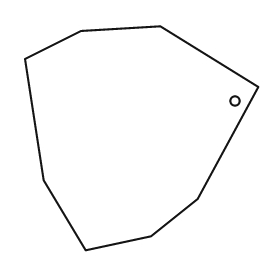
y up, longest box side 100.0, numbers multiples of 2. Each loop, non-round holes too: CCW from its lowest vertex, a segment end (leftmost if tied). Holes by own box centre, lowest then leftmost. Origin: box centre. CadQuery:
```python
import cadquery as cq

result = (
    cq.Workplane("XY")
    .moveTo(-24.0, -48.0)
    .lineTo(4.0, -42.0)
    .lineTo(24.0, -26.0)
    .lineTo(50.0, 22.0)
    .lineTo(8.0, 48.0)
    .lineTo(-26.0, 46.0)
    .lineTo(-50.0, 34.0)
    .lineTo(-42.0, -18.0)
    .close()
    .moveTo(40.0, 16.0)
    .circle(2.0)
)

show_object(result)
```